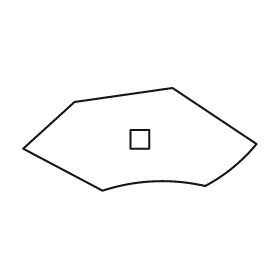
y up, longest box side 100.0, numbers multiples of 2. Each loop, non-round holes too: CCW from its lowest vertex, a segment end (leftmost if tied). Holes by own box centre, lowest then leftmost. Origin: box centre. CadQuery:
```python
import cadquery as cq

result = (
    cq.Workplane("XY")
    .moveTo(-16.0, -22.0)
    .threePointArc((6.0, -18.0), (28.0, -20.0))
    .threePointArc((40.0, -12.0), (50.0, -2.0))
    .lineTo(14.0, 22.0)
    .lineTo(-28.0, 16.0)
    .lineTo(-50.0, -4.0)
    .close()
    .moveTo(-4.0, -4.0)
    .lineTo(4.0, -4.0)
    .lineTo(4.0, 4.0)
    .lineTo(-4.0, 4.0)
    .close()
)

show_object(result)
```